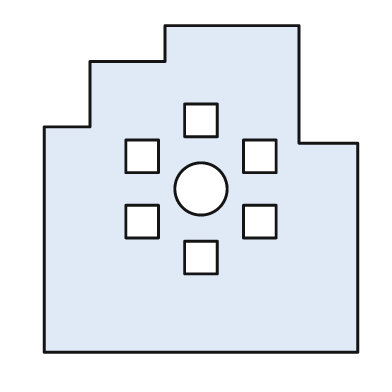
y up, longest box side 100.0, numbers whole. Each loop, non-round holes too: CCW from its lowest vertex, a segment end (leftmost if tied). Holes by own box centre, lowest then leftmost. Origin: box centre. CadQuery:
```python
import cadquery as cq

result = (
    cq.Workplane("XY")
    .moveTo(-48.0, -50.0)
    .lineTo(48.0, -50.0)
    .lineTo(48.0, 14.0)
    .lineTo(30.0, 14.0)
    .lineTo(30.0, 50.0)
    .lineTo(-11.0, 50.0)
    .lineTo(-11.0, 39.0)
    .lineTo(-34.0, 39.0)
    .lineTo(-34.0, 19.0)
    .lineTo(-48.0, 19.0)
    .close()
    .moveTo(-5.0, -26.0)
    .lineTo(5.0, -26.0)
    .lineTo(5.0, -16.0)
    .lineTo(-5.0, -16.0)
    .close()
    .moveTo(-23.0, -15.0)
    .lineTo(-13.0, -15.0)
    .lineTo(-13.0, -5.0)
    .lineTo(-23.0, -5.0)
    .close()
    .moveTo(13.0, -15.0)
    .lineTo(23.0, -15.0)
    .lineTo(23.0, -5.0)
    .lineTo(13.0, -5.0)
    .close()
    .moveTo(0.0, 0.0)
    .circle(8.0)
    .moveTo(-23.0, 5.0)
    .lineTo(-13.0, 5.0)
    .lineTo(-13.0, 15.0)
    .lineTo(-23.0, 15.0)
    .close()
    .moveTo(13.0, 5.0)
    .lineTo(23.0, 5.0)
    .lineTo(23.0, 15.0)
    .lineTo(13.0, 15.0)
    .close()
    .moveTo(-5.0, 16.0)
    .lineTo(5.0, 16.0)
    .lineTo(5.0, 26.0)
    .lineTo(-5.0, 26.0)
    .close()
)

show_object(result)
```